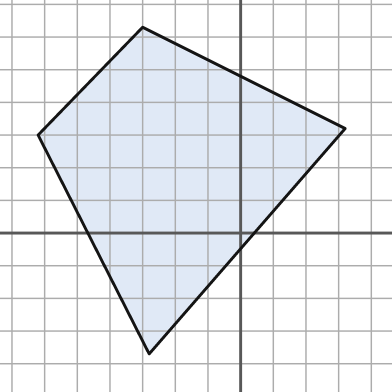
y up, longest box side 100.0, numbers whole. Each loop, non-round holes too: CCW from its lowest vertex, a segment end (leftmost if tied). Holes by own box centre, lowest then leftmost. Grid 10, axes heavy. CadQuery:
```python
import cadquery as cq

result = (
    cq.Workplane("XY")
    .moveTo(-28.0, -37.0)
    .lineTo(32.0, 32.0)
    .lineTo(-30.0, 63.0)
    .lineTo(-62.0, 30.0)
    .close()
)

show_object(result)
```